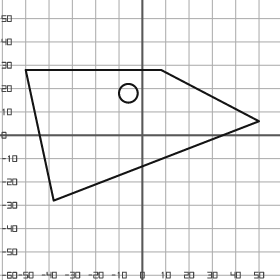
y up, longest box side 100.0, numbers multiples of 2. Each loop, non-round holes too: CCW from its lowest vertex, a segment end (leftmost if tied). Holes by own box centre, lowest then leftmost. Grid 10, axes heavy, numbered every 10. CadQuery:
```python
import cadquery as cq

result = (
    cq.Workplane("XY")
    .moveTo(-38.0, -28.0)
    .lineTo(50.0, 6.0)
    .lineTo(8.0, 28.0)
    .lineTo(-50.0, 28.0)
    .close()
    .moveTo(-6.0, 18.0)
    .circle(4.0)
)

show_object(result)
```